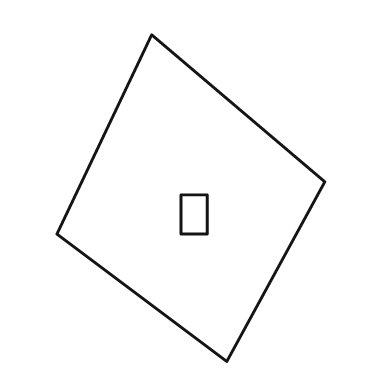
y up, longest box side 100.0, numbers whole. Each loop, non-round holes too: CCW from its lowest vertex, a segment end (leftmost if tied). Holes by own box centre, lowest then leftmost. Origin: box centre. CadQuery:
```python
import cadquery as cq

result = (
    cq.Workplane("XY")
    .moveTo(11.0, -50.0)
    .lineTo(41.0, 5.0)
    .lineTo(-12.0, 50.0)
    .lineTo(-41.0, -11.0)
    .close()
    .moveTo(-3.0, -11.0)
    .lineTo(5.0, -11.0)
    .lineTo(5.0, 1.0)
    .lineTo(-3.0, 1.0)
    .close()
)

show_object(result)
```